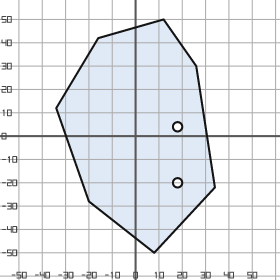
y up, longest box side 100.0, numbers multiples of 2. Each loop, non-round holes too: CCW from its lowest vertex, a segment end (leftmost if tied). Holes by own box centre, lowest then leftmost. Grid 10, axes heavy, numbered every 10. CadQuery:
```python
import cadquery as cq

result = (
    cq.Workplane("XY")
    .moveTo(8.0, -50.0)
    .lineTo(34.0, -22.0)
    .lineTo(26.0, 30.0)
    .lineTo(12.0, 50.0)
    .lineTo(-16.0, 42.0)
    .lineTo(-34.0, 12.0)
    .lineTo(-20.0, -28.0)
    .close()
    .moveTo(18.0, -20.0)
    .circle(2.0)
    .moveTo(18.0, 4.0)
    .circle(2.0)
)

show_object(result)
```